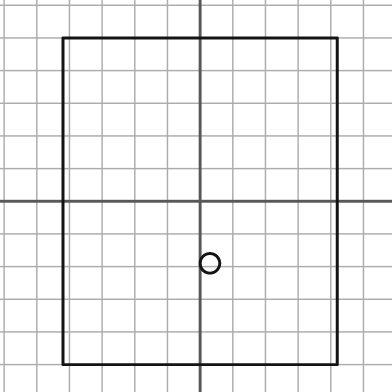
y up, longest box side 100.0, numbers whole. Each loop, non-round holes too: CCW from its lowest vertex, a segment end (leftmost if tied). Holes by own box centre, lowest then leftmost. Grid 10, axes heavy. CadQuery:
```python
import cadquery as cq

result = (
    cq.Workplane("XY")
    .moveTo(-42.0, -50.0)
    .lineTo(42.0, -50.0)
    .lineTo(42.0, 50.0)
    .lineTo(-42.0, 50.0)
    .close()
    .moveTo(3.0, -19.0)
    .circle(3.0)
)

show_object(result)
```